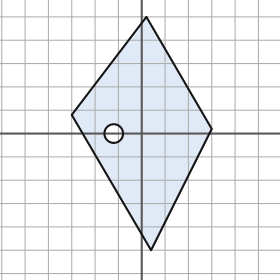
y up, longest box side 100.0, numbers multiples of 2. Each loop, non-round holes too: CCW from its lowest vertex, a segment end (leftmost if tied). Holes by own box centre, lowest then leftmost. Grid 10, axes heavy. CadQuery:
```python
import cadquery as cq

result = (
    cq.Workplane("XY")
    .moveTo(4.0, -50.0)
    .lineTo(30.0, 2.0)
    .lineTo(2.0, 50.0)
    .lineTo(-30.0, 8.0)
    .close()
    .moveTo(-12.0, 0.0)
    .circle(4.0)
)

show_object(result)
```